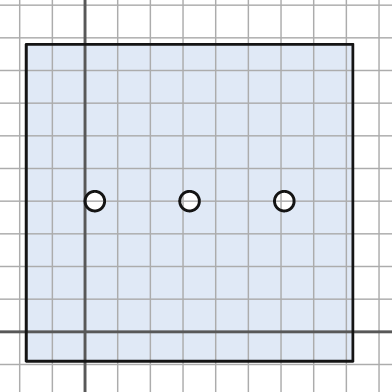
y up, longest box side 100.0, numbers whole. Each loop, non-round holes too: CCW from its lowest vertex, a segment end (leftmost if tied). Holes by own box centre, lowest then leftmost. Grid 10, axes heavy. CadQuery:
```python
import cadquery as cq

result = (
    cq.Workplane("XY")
    .moveTo(-18.0, -9.0)
    .lineTo(82.0, -9.0)
    .lineTo(82.0, 88.0)
    .lineTo(-18.0, 88.0)
    .close()
    .moveTo(3.0, 40.0)
    .circle(3.0)
    .moveTo(32.0, 40.0)
    .circle(3.0)
    .moveTo(61.0, 40.0)
    .circle(3.0)
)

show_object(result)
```